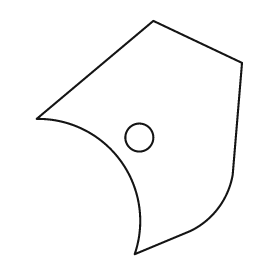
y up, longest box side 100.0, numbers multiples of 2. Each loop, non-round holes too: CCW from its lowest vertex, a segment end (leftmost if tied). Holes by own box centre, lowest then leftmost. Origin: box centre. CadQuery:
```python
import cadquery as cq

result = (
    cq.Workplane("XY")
    .moveTo(-2.0, -50.0)
    .lineTo(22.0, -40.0)
    .threePointArc((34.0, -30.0), (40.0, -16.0))
    .lineTo(44.0, 32.0)
    .lineTo(6.0, 50.0)
    .lineTo(-44.0, 8.0)
    .threePointArc((-8.0, -10.0), (-2.0, -50.0))
    .close()
    .moveTo(0.0, 0.0)
    .circle(6.0)
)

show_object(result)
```